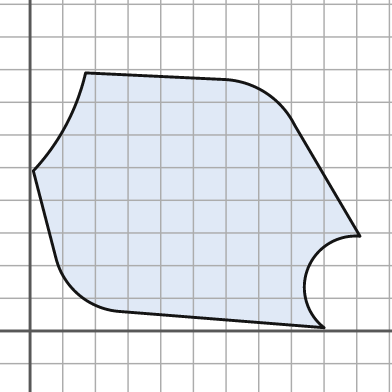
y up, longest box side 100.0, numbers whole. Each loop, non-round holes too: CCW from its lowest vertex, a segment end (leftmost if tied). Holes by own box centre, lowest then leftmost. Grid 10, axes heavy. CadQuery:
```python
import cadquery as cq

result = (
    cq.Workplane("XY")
    .moveTo(90.0, 1.0)
    .threePointArc((85.0, 19.0), (101.0, 29.0))
    .lineTo(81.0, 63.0)
    .threePointArc((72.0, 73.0), (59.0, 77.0))
    .lineTo(17.0, 79.0)
    .threePointArc((11.0, 63.0), (1.0, 49.0))
    .lineTo(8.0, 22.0)
    .threePointArc((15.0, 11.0), (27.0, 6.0))
    .close()
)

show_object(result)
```